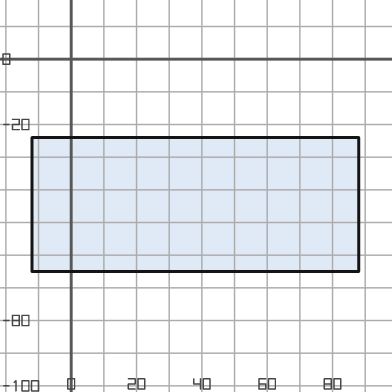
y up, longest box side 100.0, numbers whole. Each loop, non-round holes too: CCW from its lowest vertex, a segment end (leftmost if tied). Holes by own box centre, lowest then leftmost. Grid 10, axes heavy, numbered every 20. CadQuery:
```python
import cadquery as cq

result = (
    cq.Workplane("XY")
    .moveTo(-12.0, -65.0)
    .lineTo(88.0, -65.0)
    .lineTo(88.0, -24.0)
    .lineTo(-12.0, -24.0)
    .close()
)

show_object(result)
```